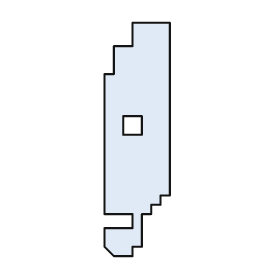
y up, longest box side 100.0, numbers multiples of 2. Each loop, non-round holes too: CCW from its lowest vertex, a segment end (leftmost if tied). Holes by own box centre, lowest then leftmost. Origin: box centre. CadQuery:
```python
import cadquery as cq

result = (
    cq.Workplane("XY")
    .moveTo(-10.0, -50.0)
    .lineTo(-2.0, -50.0)
    .lineTo(-2.0, -46.0)
    .lineTo(2.0, -46.0)
    .lineTo(2.0, -32.0)
    .lineTo(6.0, -32.0)
    .lineTo(6.0, -28.0)
    .lineTo(10.0, -28.0)
    .lineTo(10.0, -24.0)
    .lineTo(14.0, -24.0)
    .lineTo(14.0, 50.0)
    .lineTo(-2.0, 50.0)
    .lineTo(-2.0, 40.0)
    .lineTo(-10.0, 40.0)
    .lineTo(-10.0, 28.0)
    .lineTo(-14.0, 28.0)
    .lineTo(-14.0, -32.0)
    .lineTo(-2.0, -32.0)
    .lineTo(-2.0, -38.0)
    .lineTo(-14.0, -38.0)
    .lineTo(-14.0, -46.0)
    .close()
    .moveTo(-6.0, 2.0)
    .lineTo(2.0, 2.0)
    .lineTo(2.0, 10.0)
    .lineTo(-6.0, 10.0)
    .close()
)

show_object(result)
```